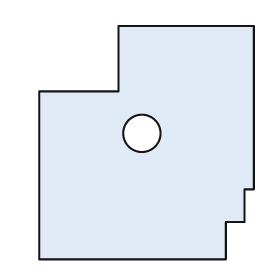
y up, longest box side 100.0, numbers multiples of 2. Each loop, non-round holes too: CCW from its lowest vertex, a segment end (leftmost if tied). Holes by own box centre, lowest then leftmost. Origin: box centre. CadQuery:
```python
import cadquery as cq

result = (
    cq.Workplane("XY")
    .moveTo(-46.0, -50.0)
    .lineTo(34.0, -50.0)
    .lineTo(34.0, -34.0)
    .lineTo(42.0, -34.0)
    .lineTo(42.0, -20.0)
    .lineTo(46.0, -20.0)
    .lineTo(46.0, 50.0)
    .lineTo(-12.0, 50.0)
    .lineTo(-12.0, 22.0)
    .lineTo(-46.0, 22.0)
    .close()
    .moveTo(-2.0, 4.0)
    .circle(8.0)
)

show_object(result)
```